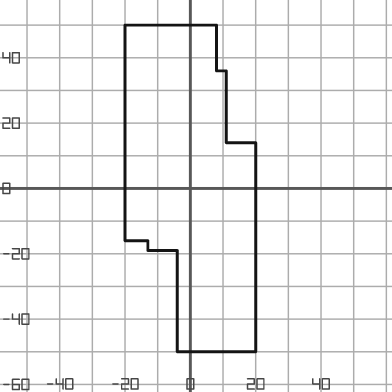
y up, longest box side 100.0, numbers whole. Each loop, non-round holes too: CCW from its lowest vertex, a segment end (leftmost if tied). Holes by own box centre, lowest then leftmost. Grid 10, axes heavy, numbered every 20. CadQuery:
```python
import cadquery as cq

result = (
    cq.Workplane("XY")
    .moveTo(-4.0, -50.0)
    .lineTo(20.0, -50.0)
    .lineTo(20.0, 14.0)
    .lineTo(11.0, 14.0)
    .lineTo(11.0, 36.0)
    .lineTo(8.0, 36.0)
    .lineTo(8.0, 50.0)
    .lineTo(-20.0, 50.0)
    .lineTo(-20.0, -16.0)
    .lineTo(-13.0, -16.0)
    .lineTo(-13.0, -19.0)
    .lineTo(-4.0, -19.0)
    .close()
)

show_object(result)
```